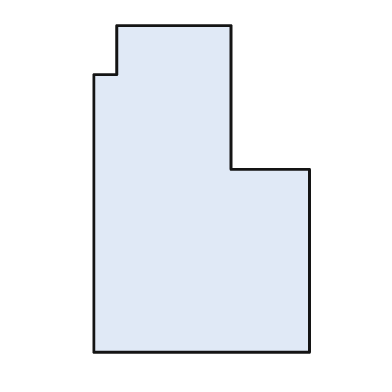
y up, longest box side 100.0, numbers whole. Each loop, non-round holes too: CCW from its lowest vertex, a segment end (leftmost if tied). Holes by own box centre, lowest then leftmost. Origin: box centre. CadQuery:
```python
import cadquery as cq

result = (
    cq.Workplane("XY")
    .moveTo(-33.0, -50.0)
    .lineTo(33.0, -50.0)
    .lineTo(33.0, 6.0)
    .lineTo(9.0, 6.0)
    .lineTo(9.0, 50.0)
    .lineTo(-26.0, 50.0)
    .lineTo(-26.0, 35.0)
    .lineTo(-33.0, 35.0)
    .close()
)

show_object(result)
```